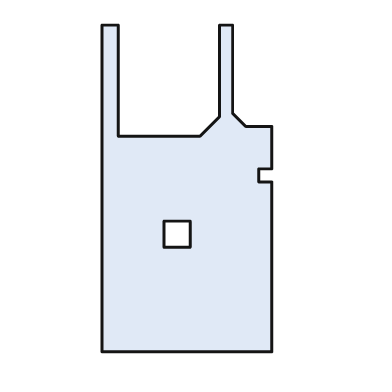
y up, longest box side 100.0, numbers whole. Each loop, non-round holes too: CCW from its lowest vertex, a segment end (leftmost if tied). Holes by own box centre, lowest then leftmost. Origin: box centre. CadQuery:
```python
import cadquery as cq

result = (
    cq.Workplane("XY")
    .moveTo(-26.0, -50.0)
    .lineTo(26.0, -50.0)
    .lineTo(26.0, 2.0)
    .lineTo(22.0, 2.0)
    .lineTo(22.0, 6.0)
    .lineTo(26.0, 6.0)
    .lineTo(26.0, 19.0)
    .lineTo(18.0, 19.0)
    .lineTo(14.0, 23.0)
    .lineTo(14.0, 50.0)
    .lineTo(10.0, 50.0)
    .lineTo(10.0, 22.0)
    .lineTo(4.0, 16.0)
    .lineTo(-21.0, 16.0)
    .lineTo(-21.0, 50.0)
    .lineTo(-26.0, 50.0)
    .close()
    .moveTo(-7.0, -18.0)
    .lineTo(1.0, -18.0)
    .lineTo(1.0, -10.0)
    .lineTo(-7.0, -10.0)
    .close()
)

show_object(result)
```